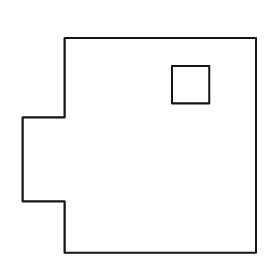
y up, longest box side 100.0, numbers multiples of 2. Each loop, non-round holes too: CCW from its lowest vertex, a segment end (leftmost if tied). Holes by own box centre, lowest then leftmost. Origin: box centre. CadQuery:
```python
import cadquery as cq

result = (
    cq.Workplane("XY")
    .moveTo(-32.0, -46.0)
    .lineTo(50.0, -46.0)
    .lineTo(50.0, 46.0)
    .lineTo(-32.0, 46.0)
    .lineTo(-32.0, 12.0)
    .lineTo(-50.0, 12.0)
    .lineTo(-50.0, -24.0)
    .lineTo(-32.0, -24.0)
    .close()
    .moveTo(14.0, 18.0)
    .lineTo(30.0, 18.0)
    .lineTo(30.0, 34.0)
    .lineTo(14.0, 34.0)
    .close()
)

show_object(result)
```